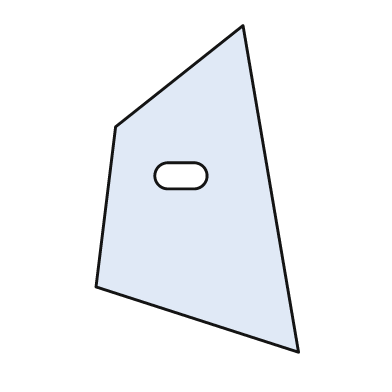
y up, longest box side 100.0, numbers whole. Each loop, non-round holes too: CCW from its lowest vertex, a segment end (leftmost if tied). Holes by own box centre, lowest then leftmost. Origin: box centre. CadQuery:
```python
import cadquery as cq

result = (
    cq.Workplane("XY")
    .moveTo(31.0, -50.0)
    .lineTo(14.0, 50.0)
    .lineTo(-25.0, 19.0)
    .lineTo(-31.0, -30.0)
    .close()
    .moveTo(-9.0, 0.0)
    .lineTo(-1.0, 0.0)
    .threePointArc((3.0, 4.0), (-1.0, 8.0))
    .lineTo(-9.0, 8.0)
    .threePointArc((-13.0, 4.0), (-9.0, 0.0))
    .close()
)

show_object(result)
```